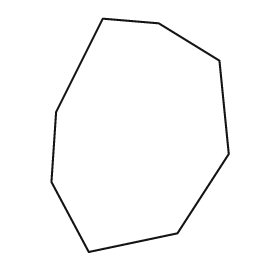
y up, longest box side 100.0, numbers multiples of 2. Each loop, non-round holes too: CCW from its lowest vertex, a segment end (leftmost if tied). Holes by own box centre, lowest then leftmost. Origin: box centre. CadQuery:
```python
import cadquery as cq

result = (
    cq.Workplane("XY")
    .moveTo(-22.0, -50.0)
    .lineTo(16.0, -42.0)
    .lineTo(38.0, -8.0)
    .lineTo(34.0, 32.0)
    .lineTo(8.0, 48.0)
    .lineTo(-16.0, 50.0)
    .lineTo(-36.0, 10.0)
    .lineTo(-38.0, -20.0)
    .close()
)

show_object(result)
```